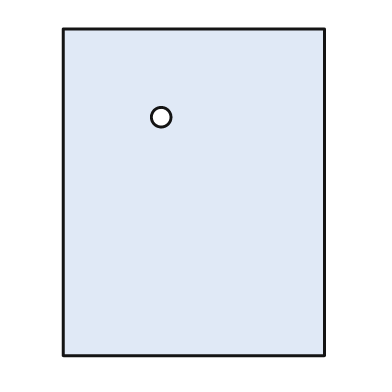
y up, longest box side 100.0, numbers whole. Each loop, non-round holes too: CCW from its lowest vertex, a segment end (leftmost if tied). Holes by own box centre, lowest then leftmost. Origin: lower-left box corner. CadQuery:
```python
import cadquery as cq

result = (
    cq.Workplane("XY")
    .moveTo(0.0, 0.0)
    .lineTo(80.0, 0.0)
    .lineTo(80.0, 100.0)
    .lineTo(0.0, 100.0)
    .close()
    .moveTo(30.0, 73.0)
    .circle(3.0)
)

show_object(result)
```